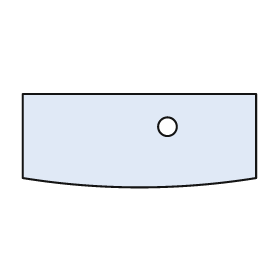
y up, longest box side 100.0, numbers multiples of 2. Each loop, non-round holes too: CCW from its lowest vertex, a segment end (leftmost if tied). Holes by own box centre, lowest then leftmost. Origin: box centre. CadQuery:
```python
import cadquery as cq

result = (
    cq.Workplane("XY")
    .moveTo(-50.0, -16.0)
    .threePointArc((0.0, -20.0), (50.0, -16.0))
    .lineTo(50.0, 20.0)
    .lineTo(-50.0, 20.0)
    .close()
    .moveTo(12.0, 6.0)
    .circle(4.0)
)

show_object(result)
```